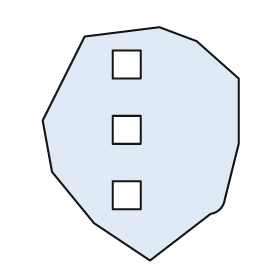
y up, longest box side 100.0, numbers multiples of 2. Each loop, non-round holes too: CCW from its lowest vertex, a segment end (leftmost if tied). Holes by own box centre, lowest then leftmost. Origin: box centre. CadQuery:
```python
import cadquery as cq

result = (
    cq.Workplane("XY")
    .moveTo(4.0, -50.0)
    .lineTo(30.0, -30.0)
    .threePointArc((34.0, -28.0), (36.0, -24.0))
    .lineTo(42.0, 0.0)
    .lineTo(42.0, 28.0)
    .lineTo(24.0, 44.0)
    .lineTo(8.0, 50.0)
    .lineTo(-24.0, 46.0)
    .lineTo(-42.0, 10.0)
    .lineTo(-38.0, -12.0)
    .lineTo(-20.0, -34.0)
    .close()
    .moveTo(-12.0, -28.0)
    .lineTo(0.0, -28.0)
    .lineTo(0.0, -16.0)
    .lineTo(-12.0, -16.0)
    .close()
    .moveTo(-12.0, 0.0)
    .lineTo(0.0, 0.0)
    .lineTo(0.0, 12.0)
    .lineTo(-12.0, 12.0)
    .close()
    .moveTo(-12.0, 28.0)
    .lineTo(0.0, 28.0)
    .lineTo(0.0, 40.0)
    .lineTo(-12.0, 40.0)
    .close()
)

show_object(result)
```